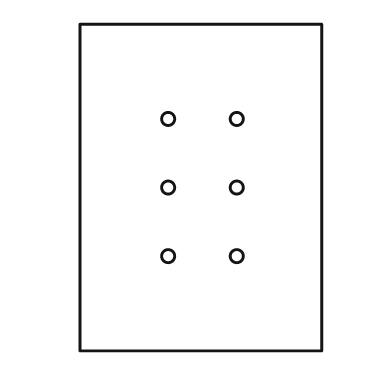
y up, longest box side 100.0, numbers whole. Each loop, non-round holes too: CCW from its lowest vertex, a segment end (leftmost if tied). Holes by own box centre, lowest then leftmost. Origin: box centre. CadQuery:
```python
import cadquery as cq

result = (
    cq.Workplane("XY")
    .moveTo(-37.0, -50.0)
    .lineTo(37.0, -50.0)
    .lineTo(37.0, 50.0)
    .lineTo(-37.0, 50.0)
    .close()
    .moveTo(-10.0, -21.0)
    .circle(2.0)
    .moveTo(11.0, -21.0)
    .circle(2.0)
    .moveTo(-10.0, 0.0)
    .circle(2.0)
    .moveTo(11.0, 0.0)
    .circle(2.0)
    .moveTo(-10.0, 21.0)
    .circle(2.0)
    .moveTo(11.0, 21.0)
    .circle(2.0)
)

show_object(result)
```